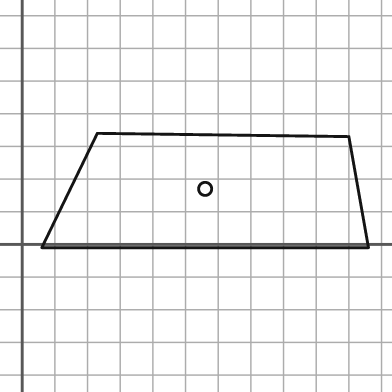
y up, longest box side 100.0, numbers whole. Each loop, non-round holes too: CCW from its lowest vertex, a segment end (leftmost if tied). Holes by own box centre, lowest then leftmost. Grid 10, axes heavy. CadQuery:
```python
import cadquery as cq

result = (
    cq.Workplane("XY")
    .moveTo(6.0, -1.0)
    .lineTo(106.0, -1.0)
    .lineTo(100.0, 33.0)
    .lineTo(23.0, 34.0)
    .close()
    .moveTo(56.0, 17.0)
    .circle(2.0)
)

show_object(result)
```